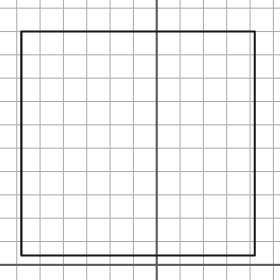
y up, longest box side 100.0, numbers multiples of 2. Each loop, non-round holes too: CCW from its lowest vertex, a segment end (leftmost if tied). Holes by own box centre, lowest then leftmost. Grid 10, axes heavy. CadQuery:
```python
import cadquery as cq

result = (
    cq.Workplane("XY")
    .moveTo(-58.0, 4.0)
    .lineTo(42.0, 4.0)
    .lineTo(42.0, 100.0)
    .lineTo(-58.0, 100.0)
    .close()
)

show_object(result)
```